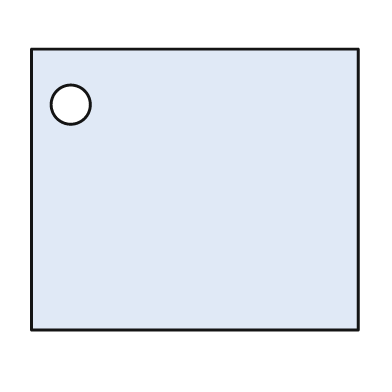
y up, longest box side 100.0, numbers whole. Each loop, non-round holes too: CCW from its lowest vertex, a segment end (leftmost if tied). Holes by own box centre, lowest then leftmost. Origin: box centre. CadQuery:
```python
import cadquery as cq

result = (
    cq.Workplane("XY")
    .moveTo(-50.0, -43.0)
    .lineTo(50.0, -43.0)
    .lineTo(50.0, 43.0)
    .lineTo(-50.0, 43.0)
    .close()
    .moveTo(-38.0, 26.0)
    .circle(6.0)
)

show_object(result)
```